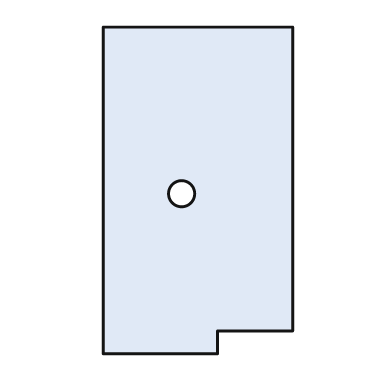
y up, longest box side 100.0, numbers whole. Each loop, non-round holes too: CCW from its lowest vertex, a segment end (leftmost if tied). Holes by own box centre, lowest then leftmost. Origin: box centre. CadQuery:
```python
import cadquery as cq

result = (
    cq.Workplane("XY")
    .moveTo(-29.0, -50.0)
    .lineTo(6.0, -50.0)
    .lineTo(6.0, -43.0)
    .lineTo(29.0, -43.0)
    .lineTo(29.0, 50.0)
    .lineTo(-29.0, 50.0)
    .close()
    .moveTo(-5.0, -1.0)
    .circle(4.0)
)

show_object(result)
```